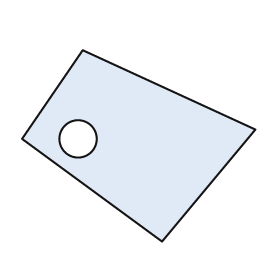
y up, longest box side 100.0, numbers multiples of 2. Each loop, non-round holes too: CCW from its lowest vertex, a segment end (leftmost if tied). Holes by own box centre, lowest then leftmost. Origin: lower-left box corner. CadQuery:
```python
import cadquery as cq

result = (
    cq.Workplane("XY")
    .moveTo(60.0, 0.0)
    .lineTo(100.0, 48.0)
    .lineTo(26.0, 82.0)
    .lineTo(0.0, 44.0)
    .close()
    .moveTo(24.0, 44.0)
    .circle(8.0)
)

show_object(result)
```